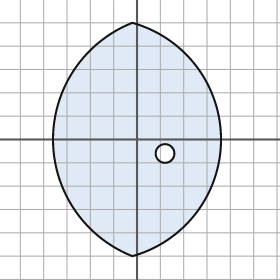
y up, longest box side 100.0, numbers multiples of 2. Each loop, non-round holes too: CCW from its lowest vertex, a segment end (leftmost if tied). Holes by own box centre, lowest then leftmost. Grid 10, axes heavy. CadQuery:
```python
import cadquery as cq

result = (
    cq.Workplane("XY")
    .moveTo(-2.0, -50.0)
    .threePointArc((36.0, 0.0), (-2.0, 50.0))
    .threePointArc((-36.0, 0.0), (-2.0, -50.0))
    .close()
    .moveTo(12.0, -6.0)
    .circle(4.0)
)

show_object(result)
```